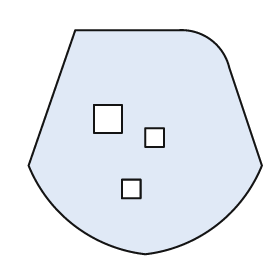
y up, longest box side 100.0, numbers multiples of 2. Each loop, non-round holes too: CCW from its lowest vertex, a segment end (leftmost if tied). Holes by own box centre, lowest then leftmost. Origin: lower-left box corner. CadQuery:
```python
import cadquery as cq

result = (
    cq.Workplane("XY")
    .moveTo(50.0, 0.0)
    .threePointArc((80.0, 12.0), (100.0, 38.0))
    .lineTo(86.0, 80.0)
    .threePointArc((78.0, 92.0), (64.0, 96.0))
    .lineTo(20.0, 96.0)
    .lineTo(0.0, 38.0)
    .threePointArc((20.0, 12.0), (50.0, 0.0))
    .close()
    .moveTo(40.0, 24.0)
    .lineTo(48.0, 24.0)
    .lineTo(48.0, 32.0)
    .lineTo(40.0, 32.0)
    .close()
    .moveTo(50.0, 46.0)
    .lineTo(58.0, 46.0)
    .lineTo(58.0, 54.0)
    .lineTo(50.0, 54.0)
    .close()
    .moveTo(28.0, 52.0)
    .lineTo(40.0, 52.0)
    .lineTo(40.0, 64.0)
    .lineTo(28.0, 64.0)
    .close()
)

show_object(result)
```